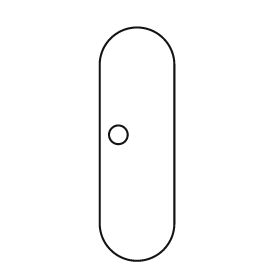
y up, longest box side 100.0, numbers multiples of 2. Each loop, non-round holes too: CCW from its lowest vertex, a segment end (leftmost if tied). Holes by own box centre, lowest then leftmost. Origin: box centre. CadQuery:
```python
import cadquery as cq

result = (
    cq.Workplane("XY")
    .moveTo(-16.0, -34.0)
    .threePointArc((0.0, -50.0), (16.0, -34.0))
    .lineTo(16.0, 34.0)
    .threePointArc((0.0, 50.0), (-16.0, 34.0))
    .close()
    .moveTo(-8.0, 4.0)
    .circle(4.0)
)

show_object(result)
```